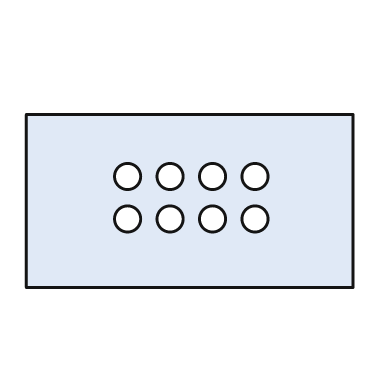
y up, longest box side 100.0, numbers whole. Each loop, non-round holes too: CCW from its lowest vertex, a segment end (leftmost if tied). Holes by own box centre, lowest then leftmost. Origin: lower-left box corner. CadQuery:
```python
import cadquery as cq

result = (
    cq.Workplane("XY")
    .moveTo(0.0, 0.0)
    .lineTo(100.0, 0.0)
    .lineTo(100.0, 53.0)
    .lineTo(0.0, 53.0)
    .close()
    .moveTo(31.0, 21.0)
    .circle(4.0)
    .moveTo(44.0, 21.0)
    .circle(4.0)
    .moveTo(57.0, 21.0)
    .circle(4.0)
    .moveTo(70.0, 21.0)
    .circle(4.0)
    .moveTo(31.0, 34.0)
    .circle(4.0)
    .moveTo(44.0, 34.0)
    .circle(4.0)
    .moveTo(57.0, 34.0)
    .circle(4.0)
    .moveTo(70.0, 34.0)
    .circle(4.0)
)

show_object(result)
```